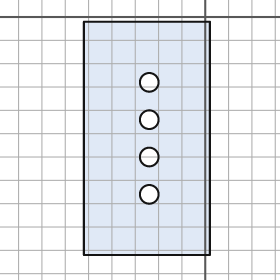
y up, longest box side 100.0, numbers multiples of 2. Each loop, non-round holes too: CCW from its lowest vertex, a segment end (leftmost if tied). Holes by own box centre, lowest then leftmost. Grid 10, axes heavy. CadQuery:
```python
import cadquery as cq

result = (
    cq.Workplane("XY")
    .moveTo(-52.0, -102.0)
    .lineTo(2.0, -102.0)
    .lineTo(2.0, -2.0)
    .lineTo(-52.0, -2.0)
    .close()
    .moveTo(-24.0, -76.0)
    .circle(4.0)
    .moveTo(-24.0, -60.0)
    .circle(4.0)
    .moveTo(-24.0, -44.0)
    .circle(4.0)
    .moveTo(-24.0, -28.0)
    .circle(4.0)
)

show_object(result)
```